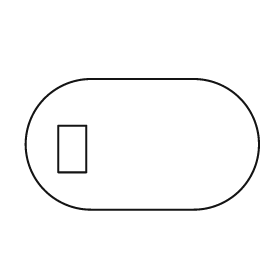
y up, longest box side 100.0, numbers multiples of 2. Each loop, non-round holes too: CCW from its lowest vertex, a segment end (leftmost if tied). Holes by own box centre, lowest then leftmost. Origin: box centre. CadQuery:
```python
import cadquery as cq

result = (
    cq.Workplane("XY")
    .moveTo(-22.0, -28.0)
    .lineTo(22.0, -28.0)
    .threePointArc((50.0, 0.0), (22.0, 28.0))
    .lineTo(-22.0, 28.0)
    .threePointArc((-50.0, 0.0), (-22.0, -28.0))
    .close()
    .moveTo(-36.0, -12.0)
    .lineTo(-24.0, -12.0)
    .lineTo(-24.0, 8.0)
    .lineTo(-36.0, 8.0)
    .close()
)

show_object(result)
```